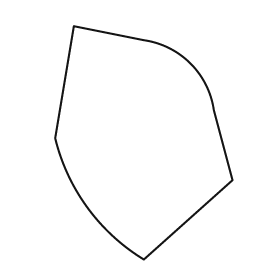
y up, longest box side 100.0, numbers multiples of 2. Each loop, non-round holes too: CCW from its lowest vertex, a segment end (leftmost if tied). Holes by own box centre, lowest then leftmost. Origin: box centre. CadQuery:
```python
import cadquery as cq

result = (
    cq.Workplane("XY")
    .moveTo(0.0, -50.0)
    .lineTo(38.0, -16.0)
    .lineTo(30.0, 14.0)
    .threePointArc((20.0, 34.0), (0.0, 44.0))
    .lineTo(-30.0, 50.0)
    .lineTo(-38.0, 2.0)
    .threePointArc((-24.0, -28.0), (0.0, -50.0))
    .close()
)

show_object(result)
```